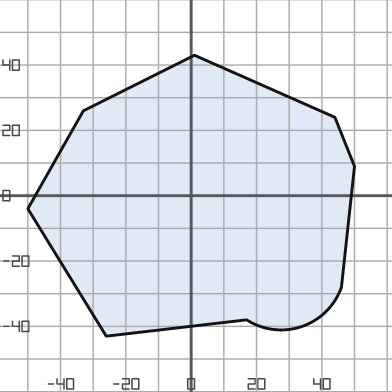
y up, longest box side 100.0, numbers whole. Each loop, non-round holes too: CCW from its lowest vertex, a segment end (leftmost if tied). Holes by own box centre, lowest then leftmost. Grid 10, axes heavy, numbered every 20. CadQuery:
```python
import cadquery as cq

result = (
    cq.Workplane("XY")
    .moveTo(-26.0, -43.0)
    .lineTo(17.0, -38.0)
    .threePointArc((34.0, -40.0), (46.0, -28.0))
    .lineTo(50.0, 9.0)
    .lineTo(44.0, 24.0)
    .lineTo(1.0, 43.0)
    .lineTo(-33.0, 26.0)
    .lineTo(-50.0, -4.0)
    .close()
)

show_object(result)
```